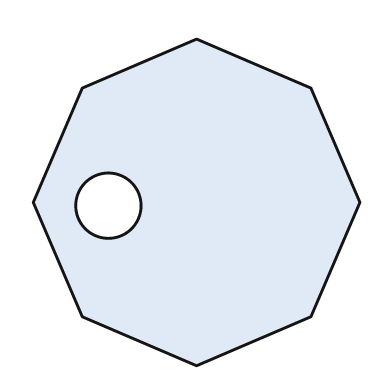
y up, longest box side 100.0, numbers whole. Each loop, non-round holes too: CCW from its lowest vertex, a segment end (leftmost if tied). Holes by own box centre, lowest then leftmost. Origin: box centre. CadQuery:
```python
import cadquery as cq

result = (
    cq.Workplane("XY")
    .moveTo(0.0, -50.0)
    .lineTo(35.0, -35.0)
    .lineTo(50.0, 0.0)
    .lineTo(35.0, 35.0)
    .lineTo(0.0, 50.0)
    .lineTo(-35.0, 35.0)
    .lineTo(-50.0, 0.0)
    .lineTo(-35.0, -35.0)
    .close()
    .moveTo(-27.0, -1.0)
    .circle(10.0)
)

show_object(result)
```